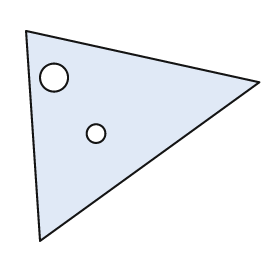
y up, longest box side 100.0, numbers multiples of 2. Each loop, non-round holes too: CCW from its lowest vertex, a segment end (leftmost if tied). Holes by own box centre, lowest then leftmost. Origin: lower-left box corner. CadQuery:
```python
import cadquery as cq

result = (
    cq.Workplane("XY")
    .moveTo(6.0, 0.0)
    .lineTo(100.0, 68.0)
    .lineTo(0.0, 90.0)
    .close()
    .moveTo(30.0, 46.0)
    .circle(4.0)
    .moveTo(12.0, 70.0)
    .circle(6.0)
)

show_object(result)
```